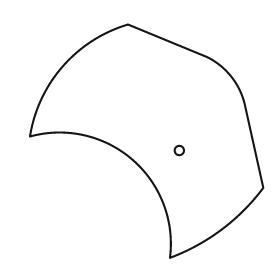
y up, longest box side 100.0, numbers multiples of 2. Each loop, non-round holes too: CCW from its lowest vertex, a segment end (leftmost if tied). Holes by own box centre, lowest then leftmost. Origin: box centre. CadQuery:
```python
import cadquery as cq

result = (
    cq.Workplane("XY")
    .moveTo(10.0, -50.0)
    .threePointArc((32.0, -38.0), (50.0, -20.0))
    .lineTo(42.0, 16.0)
    .threePointArc((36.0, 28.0), (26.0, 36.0))
    .lineTo(-8.0, 50.0)
    .threePointArc((-36.0, 32.0), (-50.0, 2.0))
    .threePointArc((-6.0, -8.0), (10.0, -50.0))
    .close()
    .moveTo(14.0, -4.0)
    .circle(2.0)
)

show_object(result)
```